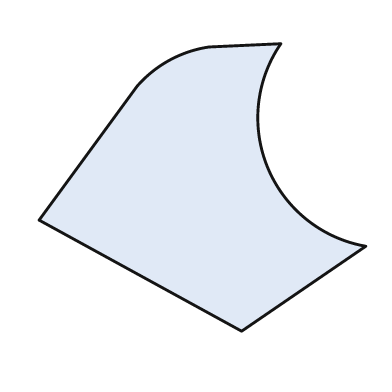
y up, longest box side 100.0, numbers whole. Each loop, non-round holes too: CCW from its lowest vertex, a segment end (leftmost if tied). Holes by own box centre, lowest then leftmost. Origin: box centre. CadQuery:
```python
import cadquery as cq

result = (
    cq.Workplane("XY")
    .moveTo(12.0, -44.0)
    .lineTo(50.0, -18.0)
    .threePointArc((20.0, 6.0), (24.0, 44.0))
    .lineTo(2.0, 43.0)
    .threePointArc((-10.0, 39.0), (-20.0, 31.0))
    .lineTo(-50.0, -10.0)
    .close()
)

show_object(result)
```